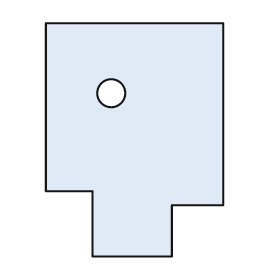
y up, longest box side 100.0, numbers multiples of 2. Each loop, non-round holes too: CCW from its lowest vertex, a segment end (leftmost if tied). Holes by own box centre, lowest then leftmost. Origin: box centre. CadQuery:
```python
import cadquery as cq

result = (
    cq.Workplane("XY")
    .moveTo(-18.0, -50.0)
    .lineTo(16.0, -50.0)
    .lineTo(16.0, -28.0)
    .lineTo(38.0, -28.0)
    .lineTo(38.0, 50.0)
    .lineTo(-38.0, 50.0)
    .lineTo(-38.0, -22.0)
    .lineTo(-18.0, -22.0)
    .close()
    .moveTo(-10.0, 20.0)
    .circle(6.0)
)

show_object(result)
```